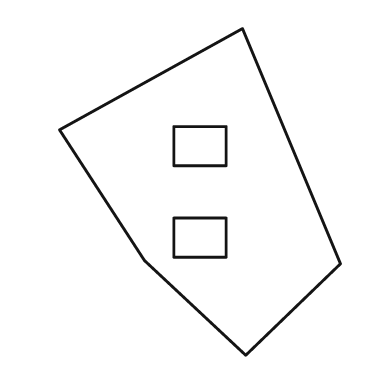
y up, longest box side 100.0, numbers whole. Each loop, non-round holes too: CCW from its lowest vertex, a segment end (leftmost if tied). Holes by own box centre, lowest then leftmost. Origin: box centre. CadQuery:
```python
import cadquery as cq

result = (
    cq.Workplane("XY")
    .moveTo(14.0, -50.0)
    .lineTo(43.0, -22.0)
    .lineTo(13.0, 50.0)
    .lineTo(-43.0, 19.0)
    .lineTo(-17.0, -21.0)
    .close()
    .moveTo(-8.0, -20.0)
    .lineTo(8.0, -20.0)
    .lineTo(8.0, -8.0)
    .lineTo(-8.0, -8.0)
    .close()
    .moveTo(-8.0, 8.0)
    .lineTo(8.0, 8.0)
    .lineTo(8.0, 20.0)
    .lineTo(-8.0, 20.0)
    .close()
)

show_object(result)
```